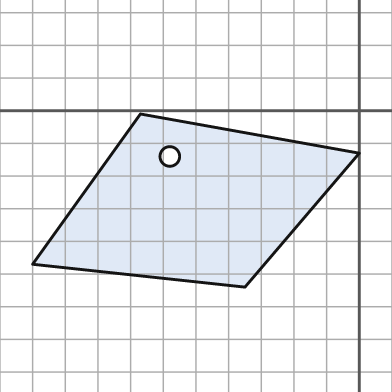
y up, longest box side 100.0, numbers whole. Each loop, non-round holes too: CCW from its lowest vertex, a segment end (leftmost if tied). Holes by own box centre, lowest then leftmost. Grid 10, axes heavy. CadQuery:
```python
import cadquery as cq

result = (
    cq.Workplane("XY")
    .moveTo(-35.0, -54.0)
    .lineTo(0.0, -13.0)
    .lineTo(-67.0, -1.0)
    .lineTo(-100.0, -47.0)
    .close()
    .moveTo(-58.0, -14.0)
    .circle(3.0)
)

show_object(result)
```